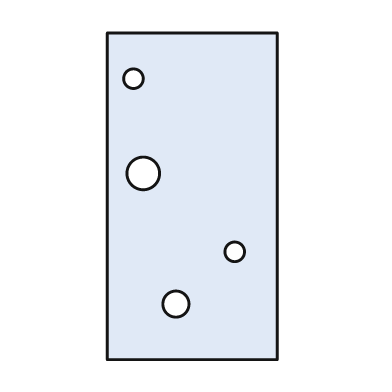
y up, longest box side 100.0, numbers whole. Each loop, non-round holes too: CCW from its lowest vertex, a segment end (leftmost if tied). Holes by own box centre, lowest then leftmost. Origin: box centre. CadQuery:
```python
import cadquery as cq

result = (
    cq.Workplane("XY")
    .moveTo(-26.0, -50.0)
    .lineTo(26.0, -50.0)
    .lineTo(26.0, 50.0)
    .lineTo(-26.0, 50.0)
    .close()
    .moveTo(-5.0, -33.0)
    .circle(4.0)
    .moveTo(13.0, -17.0)
    .circle(3.0)
    .moveTo(-15.0, 7.0)
    .circle(5.0)
    .moveTo(-18.0, 36.0)
    .circle(3.0)
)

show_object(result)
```